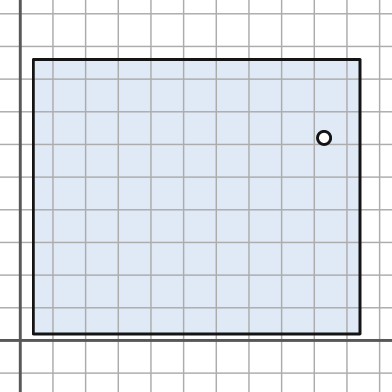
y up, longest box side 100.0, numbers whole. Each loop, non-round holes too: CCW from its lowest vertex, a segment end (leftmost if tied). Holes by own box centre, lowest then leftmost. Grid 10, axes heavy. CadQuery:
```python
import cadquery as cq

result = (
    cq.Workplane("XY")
    .moveTo(4.0, 2.0)
    .lineTo(104.0, 2.0)
    .lineTo(104.0, 86.0)
    .lineTo(4.0, 86.0)
    .close()
    .moveTo(93.0, 62.0)
    .circle(2.0)
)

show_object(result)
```